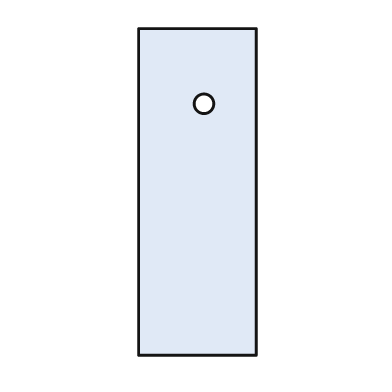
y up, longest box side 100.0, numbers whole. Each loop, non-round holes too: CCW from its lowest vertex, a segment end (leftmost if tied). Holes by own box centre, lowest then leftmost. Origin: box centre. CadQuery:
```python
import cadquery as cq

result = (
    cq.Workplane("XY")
    .moveTo(-18.0, -50.0)
    .lineTo(18.0, -50.0)
    .lineTo(18.0, 50.0)
    .lineTo(-18.0, 50.0)
    .close()
    .moveTo(2.0, 27.0)
    .circle(3.0)
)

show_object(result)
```